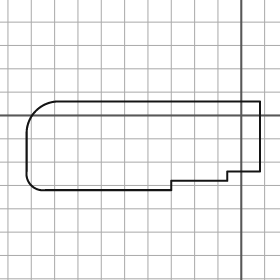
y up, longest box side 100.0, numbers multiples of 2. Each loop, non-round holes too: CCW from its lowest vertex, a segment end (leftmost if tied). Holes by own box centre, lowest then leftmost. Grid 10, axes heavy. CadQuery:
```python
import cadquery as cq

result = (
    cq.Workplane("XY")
    .moveTo(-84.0, -32.0)
    .lineTo(-30.0, -32.0)
    .lineTo(-30.0, -28.0)
    .lineTo(-6.0, -28.0)
    .lineTo(-6.0, -24.0)
    .lineTo(8.0, -24.0)
    .lineTo(8.0, 6.0)
    .lineTo(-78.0, 6.0)
    .threePointArc((-88.0, 2.0), (-92.0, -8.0))
    .lineTo(-92.0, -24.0)
    .threePointArc((-90.0, -30.0), (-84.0, -32.0))
    .close()
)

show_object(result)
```